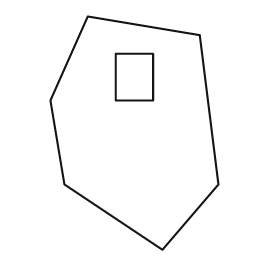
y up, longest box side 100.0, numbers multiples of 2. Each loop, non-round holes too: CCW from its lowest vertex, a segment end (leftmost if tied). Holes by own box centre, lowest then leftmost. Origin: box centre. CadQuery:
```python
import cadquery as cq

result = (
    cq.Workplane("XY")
    .moveTo(12.0, -50.0)
    .lineTo(36.0, -22.0)
    .lineTo(28.0, 42.0)
    .lineTo(-20.0, 50.0)
    .lineTo(-36.0, 14.0)
    .lineTo(-30.0, -22.0)
    .close()
    .moveTo(-8.0, 14.0)
    .lineTo(8.0, 14.0)
    .lineTo(8.0, 34.0)
    .lineTo(-8.0, 34.0)
    .close()
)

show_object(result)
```